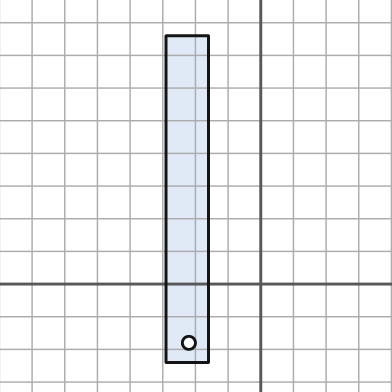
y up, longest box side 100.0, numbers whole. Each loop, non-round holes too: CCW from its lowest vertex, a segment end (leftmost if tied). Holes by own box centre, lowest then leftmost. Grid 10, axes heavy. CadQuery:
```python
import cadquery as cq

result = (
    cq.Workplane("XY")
    .moveTo(-29.0, -24.0)
    .lineTo(-16.0, -24.0)
    .lineTo(-16.0, 76.0)
    .lineTo(-29.0, 76.0)
    .close()
    .moveTo(-22.0, -18.0)
    .circle(2.0)
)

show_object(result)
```